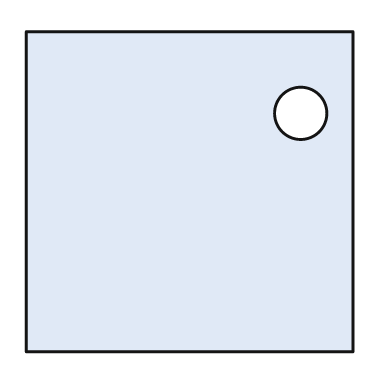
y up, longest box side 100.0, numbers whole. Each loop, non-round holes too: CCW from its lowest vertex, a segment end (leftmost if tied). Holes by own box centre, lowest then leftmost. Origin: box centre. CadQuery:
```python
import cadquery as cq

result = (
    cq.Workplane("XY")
    .moveTo(-50.0, -49.0)
    .lineTo(50.0, -49.0)
    .lineTo(50.0, 49.0)
    .lineTo(-50.0, 49.0)
    .close()
    .moveTo(34.0, 24.0)
    .circle(8.0)
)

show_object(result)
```